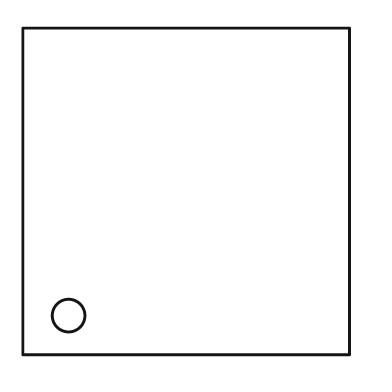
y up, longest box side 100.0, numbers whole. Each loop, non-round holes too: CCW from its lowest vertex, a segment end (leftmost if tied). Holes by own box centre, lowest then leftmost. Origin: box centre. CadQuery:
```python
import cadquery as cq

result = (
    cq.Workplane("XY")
    .moveTo(-50.0, -50.0)
    .lineTo(50.0, -50.0)
    .lineTo(50.0, 50.0)
    .lineTo(-50.0, 50.0)
    .close()
    .moveTo(-36.0, -38.0)
    .circle(5.0)
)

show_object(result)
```